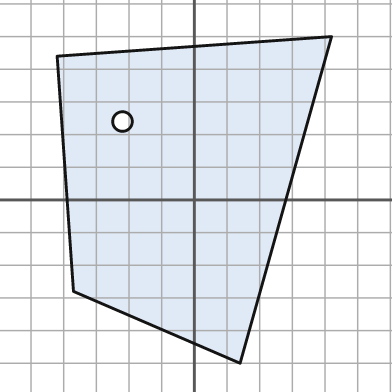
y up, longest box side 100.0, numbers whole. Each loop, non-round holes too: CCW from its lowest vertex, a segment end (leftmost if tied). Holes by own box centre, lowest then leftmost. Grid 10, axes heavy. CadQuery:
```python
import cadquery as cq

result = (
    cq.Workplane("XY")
    .moveTo(14.0, -50.0)
    .lineTo(42.0, 50.0)
    .lineTo(-42.0, 44.0)
    .lineTo(-37.0, -28.0)
    .close()
    .moveTo(-22.0, 24.0)
    .circle(3.0)
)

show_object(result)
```